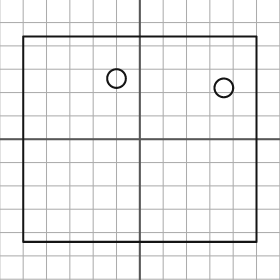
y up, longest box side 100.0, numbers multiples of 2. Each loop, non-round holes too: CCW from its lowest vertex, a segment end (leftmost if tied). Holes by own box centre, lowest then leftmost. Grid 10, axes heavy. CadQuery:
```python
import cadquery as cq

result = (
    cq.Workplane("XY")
    .moveTo(-50.0, -44.0)
    .lineTo(50.0, -44.0)
    .lineTo(50.0, 44.0)
    .lineTo(-50.0, 44.0)
    .close()
    .moveTo(36.0, 22.0)
    .circle(4.0)
    .moveTo(-10.0, 26.0)
    .circle(4.0)
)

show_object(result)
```